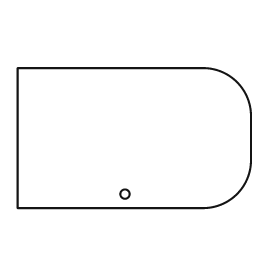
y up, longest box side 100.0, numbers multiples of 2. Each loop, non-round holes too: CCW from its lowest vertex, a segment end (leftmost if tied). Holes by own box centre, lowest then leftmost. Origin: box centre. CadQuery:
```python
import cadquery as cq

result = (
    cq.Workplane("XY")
    .moveTo(-50.0, -30.0)
    .lineTo(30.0, -30.0)
    .threePointArc((44.0, -24.0), (50.0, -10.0))
    .lineTo(50.0, 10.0)
    .threePointArc((44.0, 24.0), (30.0, 30.0))
    .lineTo(-50.0, 30.0)
    .close()
    .moveTo(-4.0, -24.0)
    .circle(2.0)
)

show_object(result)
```